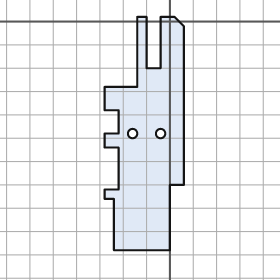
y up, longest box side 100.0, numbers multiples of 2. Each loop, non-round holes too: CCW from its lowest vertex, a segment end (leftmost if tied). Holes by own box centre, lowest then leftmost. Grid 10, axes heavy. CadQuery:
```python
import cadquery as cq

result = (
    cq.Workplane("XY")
    .moveTo(-24.0, -98.0)
    .lineTo(0.0, -98.0)
    .lineTo(0.0, -70.0)
    .lineTo(6.0, -70.0)
    .lineTo(6.0, -2.0)
    .lineTo(2.0, 2.0)
    .lineTo(-4.0, 2.0)
    .lineTo(-4.0, -20.0)
    .lineTo(-10.0, -20.0)
    .lineTo(-10.0, 2.0)
    .lineTo(-14.0, 2.0)
    .lineTo(-14.0, -28.0)
    .lineTo(-28.0, -28.0)
    .lineTo(-28.0, -38.0)
    .lineTo(-22.0, -38.0)
    .lineTo(-22.0, -48.0)
    .lineTo(-28.0, -48.0)
    .lineTo(-28.0, -54.0)
    .lineTo(-22.0, -54.0)
    .lineTo(-22.0, -72.0)
    .lineTo(-28.0, -72.0)
    .lineTo(-28.0, -76.0)
    .lineTo(-24.0, -76.0)
    .close()
    .moveTo(-16.0, -48.0)
    .circle(2.0)
    .moveTo(-4.0, -48.0)
    .circle(2.0)
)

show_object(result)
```